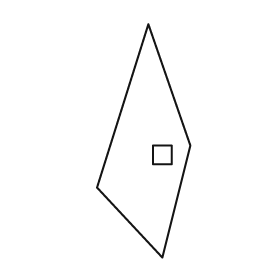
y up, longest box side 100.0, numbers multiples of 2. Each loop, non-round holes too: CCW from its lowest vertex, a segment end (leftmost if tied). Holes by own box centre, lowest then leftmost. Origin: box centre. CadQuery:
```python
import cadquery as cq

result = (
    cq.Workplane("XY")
    .moveTo(8.0, -50.0)
    .lineTo(20.0, -2.0)
    .lineTo(2.0, 50.0)
    .lineTo(-20.0, -20.0)
    .close()
    .moveTo(4.0, -10.0)
    .lineTo(12.0, -10.0)
    .lineTo(12.0, -2.0)
    .lineTo(4.0, -2.0)
    .close()
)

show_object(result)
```